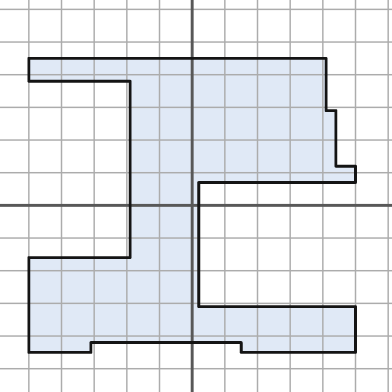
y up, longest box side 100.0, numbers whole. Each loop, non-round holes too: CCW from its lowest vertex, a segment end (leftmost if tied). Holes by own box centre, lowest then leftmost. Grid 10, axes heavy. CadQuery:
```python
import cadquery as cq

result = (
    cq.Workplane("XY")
    .moveTo(-50.0, -45.0)
    .lineTo(-31.0, -45.0)
    .lineTo(-31.0, -42.0)
    .lineTo(15.0, -42.0)
    .lineTo(15.0, -45.0)
    .lineTo(50.0, -45.0)
    .lineTo(50.0, -31.0)
    .lineTo(2.0, -31.0)
    .lineTo(2.0, 7.0)
    .lineTo(50.0, 7.0)
    .lineTo(50.0, 12.0)
    .lineTo(44.0, 12.0)
    .lineTo(44.0, 29.0)
    .lineTo(41.0, 29.0)
    .lineTo(41.0, 45.0)
    .lineTo(-50.0, 45.0)
    .lineTo(-50.0, 38.0)
    .lineTo(-19.0, 38.0)
    .lineTo(-19.0, -16.0)
    .lineTo(-50.0, -16.0)
    .close()
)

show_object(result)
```